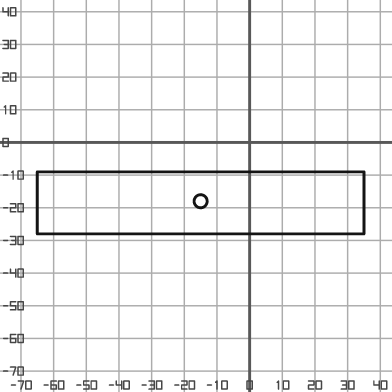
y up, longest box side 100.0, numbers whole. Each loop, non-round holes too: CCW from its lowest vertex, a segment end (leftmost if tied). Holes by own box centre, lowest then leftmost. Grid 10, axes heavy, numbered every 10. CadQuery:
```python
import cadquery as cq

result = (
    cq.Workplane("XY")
    .moveTo(-65.0, -28.0)
    .lineTo(35.0, -28.0)
    .lineTo(35.0, -9.0)
    .lineTo(-65.0, -9.0)
    .close()
    .moveTo(-15.0, -18.0)
    .circle(2.0)
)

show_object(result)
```